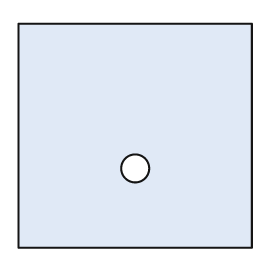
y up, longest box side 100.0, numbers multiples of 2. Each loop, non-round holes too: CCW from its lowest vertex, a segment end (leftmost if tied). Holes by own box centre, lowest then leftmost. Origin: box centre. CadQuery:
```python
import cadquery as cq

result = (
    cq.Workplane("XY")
    .moveTo(-50.0, -48.0)
    .lineTo(50.0, -48.0)
    .lineTo(50.0, 48.0)
    .lineTo(-50.0, 48.0)
    .close()
    .moveTo(0.0, -14.0)
    .circle(6.0)
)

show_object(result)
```